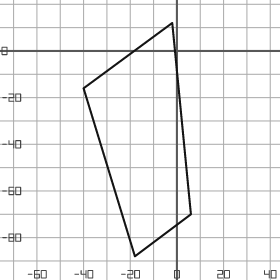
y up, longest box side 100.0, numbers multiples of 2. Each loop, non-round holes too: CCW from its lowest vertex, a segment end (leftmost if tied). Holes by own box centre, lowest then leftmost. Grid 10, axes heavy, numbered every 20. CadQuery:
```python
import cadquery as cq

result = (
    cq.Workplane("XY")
    .moveTo(-18.0, -88.0)
    .lineTo(6.0, -70.0)
    .lineTo(-2.0, 12.0)
    .lineTo(-40.0, -16.0)
    .close()
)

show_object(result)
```